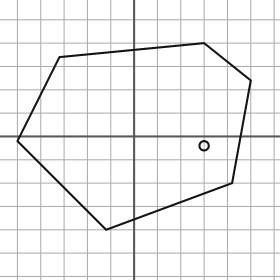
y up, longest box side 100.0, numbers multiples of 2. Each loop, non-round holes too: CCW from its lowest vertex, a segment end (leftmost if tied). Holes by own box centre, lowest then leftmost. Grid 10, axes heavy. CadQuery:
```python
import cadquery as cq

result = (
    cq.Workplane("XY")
    .moveTo(-12.0, -40.0)
    .lineTo(42.0, -20.0)
    .lineTo(50.0, 24.0)
    .lineTo(30.0, 40.0)
    .lineTo(-32.0, 34.0)
    .lineTo(-50.0, -2.0)
    .close()
    .moveTo(30.0, -4.0)
    .circle(2.0)
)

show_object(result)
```